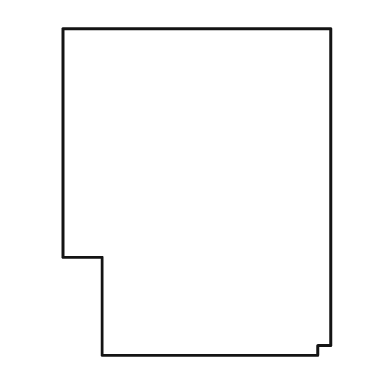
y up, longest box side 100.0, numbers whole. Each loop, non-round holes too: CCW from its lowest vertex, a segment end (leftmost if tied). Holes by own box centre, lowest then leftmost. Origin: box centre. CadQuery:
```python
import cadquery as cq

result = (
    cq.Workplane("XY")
    .moveTo(-29.0, -50.0)
    .lineTo(37.0, -50.0)
    .lineTo(37.0, -47.0)
    .lineTo(41.0, -47.0)
    .lineTo(41.0, 50.0)
    .lineTo(-41.0, 50.0)
    .lineTo(-41.0, -20.0)
    .lineTo(-29.0, -20.0)
    .close()
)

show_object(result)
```